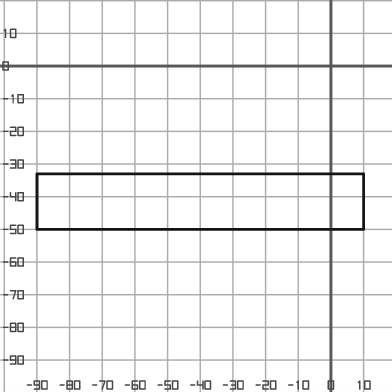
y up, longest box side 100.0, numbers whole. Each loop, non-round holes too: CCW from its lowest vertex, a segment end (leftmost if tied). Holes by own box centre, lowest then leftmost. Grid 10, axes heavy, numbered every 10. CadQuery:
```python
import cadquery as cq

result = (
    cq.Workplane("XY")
    .moveTo(-90.0, -50.0)
    .lineTo(10.0, -50.0)
    .lineTo(10.0, -33.0)
    .lineTo(-90.0, -33.0)
    .close()
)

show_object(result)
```